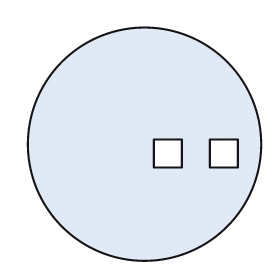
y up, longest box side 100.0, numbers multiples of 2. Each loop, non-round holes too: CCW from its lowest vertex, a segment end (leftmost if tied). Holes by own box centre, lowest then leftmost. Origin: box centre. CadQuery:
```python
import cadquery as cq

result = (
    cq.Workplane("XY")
    .moveTo(0.0, 0.0)
    .circle(50.0)
    .moveTo(4.0, -10.0)
    .lineTo(16.0, -10.0)
    .lineTo(16.0, 2.0)
    .lineTo(4.0, 2.0)
    .close()
    .moveTo(28.0, -10.0)
    .lineTo(40.0, -10.0)
    .lineTo(40.0, 2.0)
    .lineTo(28.0, 2.0)
    .close()
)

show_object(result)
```